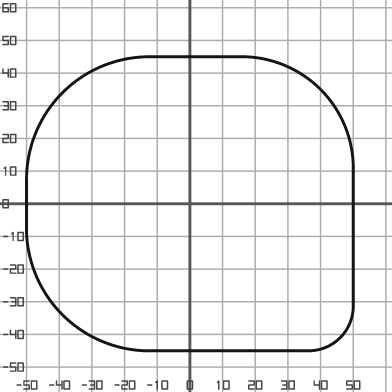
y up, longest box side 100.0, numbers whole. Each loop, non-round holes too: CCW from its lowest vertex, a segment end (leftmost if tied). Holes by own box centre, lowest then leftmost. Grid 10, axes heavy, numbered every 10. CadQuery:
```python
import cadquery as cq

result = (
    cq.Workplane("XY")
    .moveTo(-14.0, -45.0)
    .lineTo(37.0, -45.0)
    .threePointArc((46.0, -41.0), (50.0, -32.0))
    .lineTo(50.0, 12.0)
    .threePointArc((40.0, 35.0), (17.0, 45.0))
    .lineTo(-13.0, 45.0)
    .threePointArc((-39.0, 34.0), (-50.0, 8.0))
    .lineTo(-50.0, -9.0)
    .threePointArc((-39.0, -34.0), (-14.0, -45.0))
    .close()
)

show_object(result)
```